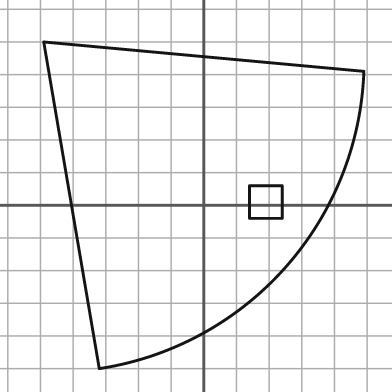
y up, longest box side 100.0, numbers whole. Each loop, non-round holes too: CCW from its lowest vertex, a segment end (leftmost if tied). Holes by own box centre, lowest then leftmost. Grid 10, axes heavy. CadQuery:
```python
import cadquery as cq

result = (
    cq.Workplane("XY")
    .moveTo(-32.0, -50.0)
    .threePointArc((25.0, -19.0), (49.0, 41.0))
    .lineTo(-49.0, 50.0)
    .close()
    .moveTo(14.0, -4.0)
    .lineTo(24.0, -4.0)
    .lineTo(24.0, 6.0)
    .lineTo(14.0, 6.0)
    .close()
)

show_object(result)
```